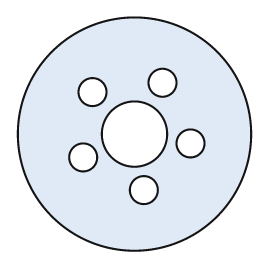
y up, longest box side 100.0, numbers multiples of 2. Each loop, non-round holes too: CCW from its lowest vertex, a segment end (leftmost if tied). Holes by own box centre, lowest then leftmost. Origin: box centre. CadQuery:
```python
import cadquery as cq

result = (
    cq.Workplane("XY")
    .moveTo(0.0, 0.0)
    .circle(50.0)
    .moveTo(4.0, -24.0)
    .circle(6.0)
    .moveTo(-22.0, -10.0)
    .circle(6.0)
    .moveTo(24.0, -4.0)
    .circle(6.0)
    .moveTo(0.0, 0.0)
    .circle(14.0)
    .moveTo(-18.0, 18.0)
    .circle(6.0)
    .moveTo(12.0, 22.0)
    .circle(6.0)
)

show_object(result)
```